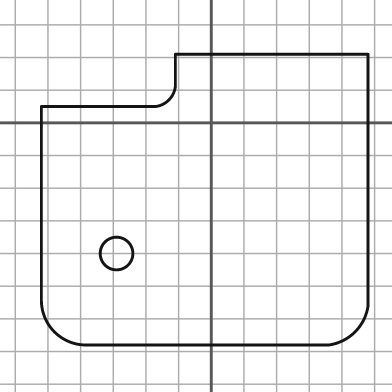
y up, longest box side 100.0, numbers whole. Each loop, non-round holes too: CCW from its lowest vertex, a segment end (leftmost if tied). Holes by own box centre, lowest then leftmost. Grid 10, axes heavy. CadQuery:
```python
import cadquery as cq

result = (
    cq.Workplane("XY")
    .moveTo(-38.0, -68.0)
    .lineTo(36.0, -68.0)
    .threePointArc((44.0, -64.0), (48.0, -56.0))
    .lineTo(48.0, 21.0)
    .lineTo(-11.0, 21.0)
    .lineTo(-11.0, 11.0)
    .threePointArc((-13.0, 7.0), (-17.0, 5.0))
    .lineTo(-52.0, 5.0)
    .lineTo(-52.0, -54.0)
    .threePointArc((-48.0, -64.0), (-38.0, -68.0))
    .close()
    .moveTo(-29.0, -40.0)
    .circle(5.0)
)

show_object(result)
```